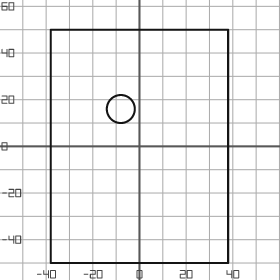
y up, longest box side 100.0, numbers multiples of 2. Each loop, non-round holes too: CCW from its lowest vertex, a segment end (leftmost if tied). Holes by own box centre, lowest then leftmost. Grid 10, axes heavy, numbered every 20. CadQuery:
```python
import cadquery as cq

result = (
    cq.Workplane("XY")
    .moveTo(-38.0, -50.0)
    .lineTo(38.0, -50.0)
    .lineTo(38.0, 50.0)
    .lineTo(-38.0, 50.0)
    .close()
    .moveTo(-8.0, 16.0)
    .circle(6.0)
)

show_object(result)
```